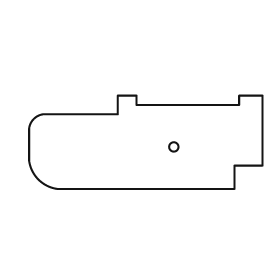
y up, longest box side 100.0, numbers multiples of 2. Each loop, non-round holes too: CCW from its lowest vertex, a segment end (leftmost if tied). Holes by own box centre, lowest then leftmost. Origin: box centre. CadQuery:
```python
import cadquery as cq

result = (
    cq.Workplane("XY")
    .moveTo(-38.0, -20.0)
    .lineTo(38.0, -20.0)
    .lineTo(38.0, -10.0)
    .lineTo(50.0, -10.0)
    .lineTo(50.0, 20.0)
    .lineTo(40.0, 20.0)
    .lineTo(40.0, 16.0)
    .lineTo(-4.0, 16.0)
    .lineTo(-4.0, 20.0)
    .lineTo(-12.0, 20.0)
    .lineTo(-12.0, 12.0)
    .lineTo(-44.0, 12.0)
    .threePointArc((-48.0, 10.0), (-50.0, 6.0))
    .lineTo(-50.0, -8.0)
    .threePointArc((-46.0, -16.0), (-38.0, -20.0))
    .close()
    .moveTo(12.0, -2.0)
    .circle(2.0)
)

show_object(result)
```